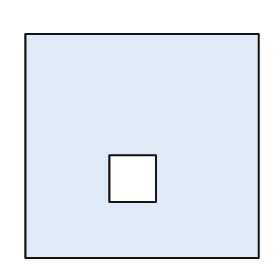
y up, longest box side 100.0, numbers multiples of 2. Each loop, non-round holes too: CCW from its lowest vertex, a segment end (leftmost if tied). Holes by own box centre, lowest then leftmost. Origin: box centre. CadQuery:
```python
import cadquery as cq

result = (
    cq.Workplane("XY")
    .moveTo(-50.0, -48.0)
    .lineTo(50.0, -48.0)
    .lineTo(50.0, 48.0)
    .lineTo(-50.0, 48.0)
    .close()
    .moveTo(-14.0, -24.0)
    .lineTo(6.0, -24.0)
    .lineTo(6.0, -4.0)
    .lineTo(-14.0, -4.0)
    .close()
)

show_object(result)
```